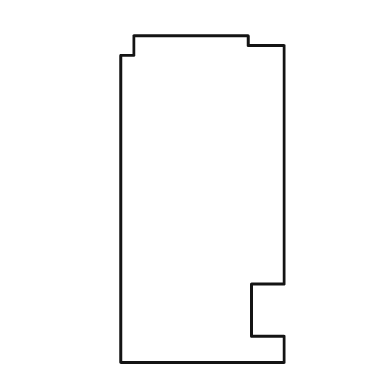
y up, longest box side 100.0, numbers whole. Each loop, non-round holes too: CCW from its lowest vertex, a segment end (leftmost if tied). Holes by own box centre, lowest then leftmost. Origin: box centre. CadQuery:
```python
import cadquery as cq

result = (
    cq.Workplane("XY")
    .moveTo(-25.0, -50.0)
    .lineTo(25.0, -50.0)
    .lineTo(25.0, -42.0)
    .lineTo(15.0, -42.0)
    .lineTo(15.0, -26.0)
    .lineTo(25.0, -26.0)
    .lineTo(25.0, 47.0)
    .lineTo(14.0, 47.0)
    .lineTo(14.0, 50.0)
    .lineTo(-21.0, 50.0)
    .lineTo(-21.0, 44.0)
    .lineTo(-25.0, 44.0)
    .close()
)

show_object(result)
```